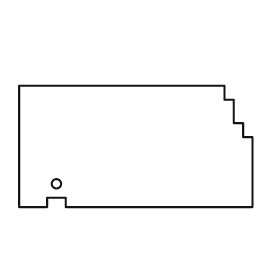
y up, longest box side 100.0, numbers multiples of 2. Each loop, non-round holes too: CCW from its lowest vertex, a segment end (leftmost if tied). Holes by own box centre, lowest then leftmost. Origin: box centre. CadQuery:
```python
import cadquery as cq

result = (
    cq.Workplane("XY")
    .moveTo(-50.0, -26.0)
    .lineTo(-38.0, -26.0)
    .lineTo(-38.0, -22.0)
    .lineTo(-30.0, -22.0)
    .lineTo(-30.0, -26.0)
    .lineTo(50.0, -26.0)
    .lineTo(50.0, 4.0)
    .lineTo(46.0, 4.0)
    .lineTo(46.0, 10.0)
    .lineTo(42.0, 10.0)
    .lineTo(42.0, 20.0)
    .lineTo(38.0, 20.0)
    .lineTo(38.0, 26.0)
    .lineTo(-50.0, 26.0)
    .close()
    .moveTo(-34.0, -16.0)
    .circle(2.0)
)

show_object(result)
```